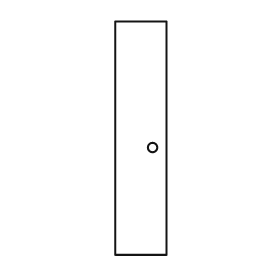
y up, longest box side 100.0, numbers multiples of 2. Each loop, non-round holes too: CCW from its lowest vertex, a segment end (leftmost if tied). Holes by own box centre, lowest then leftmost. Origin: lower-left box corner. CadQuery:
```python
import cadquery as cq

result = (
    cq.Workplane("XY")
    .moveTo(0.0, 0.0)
    .lineTo(22.0, 0.0)
    .lineTo(22.0, 100.0)
    .lineTo(0.0, 100.0)
    .close()
    .moveTo(16.0, 46.0)
    .circle(2.0)
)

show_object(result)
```